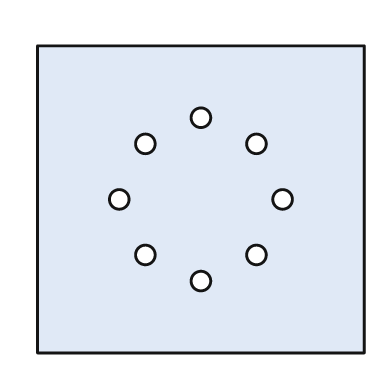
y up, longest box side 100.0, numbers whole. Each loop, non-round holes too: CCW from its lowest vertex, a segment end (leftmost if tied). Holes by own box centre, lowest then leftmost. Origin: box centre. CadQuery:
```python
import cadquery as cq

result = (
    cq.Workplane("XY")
    .moveTo(-50.0, -47.0)
    .lineTo(50.0, -47.0)
    .lineTo(50.0, 47.0)
    .lineTo(-50.0, 47.0)
    .close()
    .moveTo(0.0, -25.0)
    .circle(3.0)
    .moveTo(-17.0, -17.0)
    .circle(3.0)
    .moveTo(17.0, -17.0)
    .circle(3.0)
    .moveTo(-25.0, 0.0)
    .circle(3.0)
    .moveTo(25.0, 0.0)
    .circle(3.0)
    .moveTo(-17.0, 17.0)
    .circle(3.0)
    .moveTo(17.0, 17.0)
    .circle(3.0)
    .moveTo(0.0, 25.0)
    .circle(3.0)
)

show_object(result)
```